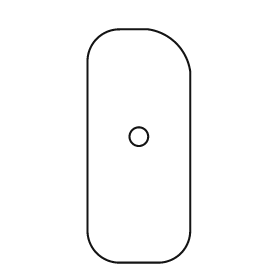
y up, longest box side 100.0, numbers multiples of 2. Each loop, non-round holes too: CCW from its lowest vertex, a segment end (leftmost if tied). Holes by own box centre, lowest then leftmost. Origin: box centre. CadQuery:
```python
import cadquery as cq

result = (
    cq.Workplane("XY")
    .moveTo(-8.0, -50.0)
    .lineTo(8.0, -50.0)
    .threePointArc((18.0, -46.0), (22.0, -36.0))
    .lineTo(22.0, 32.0)
    .threePointArc((16.0, 44.0), (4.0, 50.0))
    .lineTo(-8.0, 50.0)
    .threePointArc((-18.0, 46.0), (-22.0, 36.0))
    .lineTo(-22.0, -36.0)
    .threePointArc((-18.0, -46.0), (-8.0, -50.0))
    .close()
    .moveTo(0.0, 4.0)
    .circle(4.0)
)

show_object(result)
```